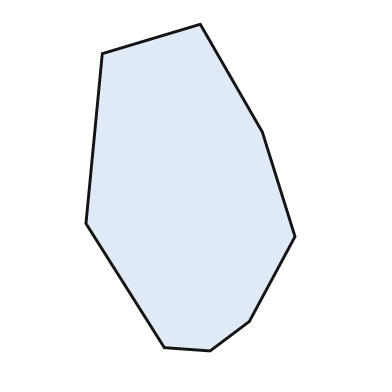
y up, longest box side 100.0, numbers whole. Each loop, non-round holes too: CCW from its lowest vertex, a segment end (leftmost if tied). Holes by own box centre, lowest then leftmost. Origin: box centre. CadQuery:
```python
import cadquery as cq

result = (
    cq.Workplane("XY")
    .moveTo(6.0, -50.0)
    .lineTo(18.0, -41.0)
    .lineTo(32.0, -15.0)
    .lineTo(22.0, 17.0)
    .lineTo(3.0, 50.0)
    .lineTo(-27.0, 41.0)
    .lineTo(-32.0, -11.0)
    .lineTo(-8.0, -49.0)
    .close()
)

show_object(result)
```